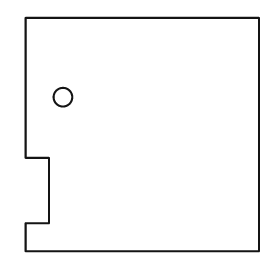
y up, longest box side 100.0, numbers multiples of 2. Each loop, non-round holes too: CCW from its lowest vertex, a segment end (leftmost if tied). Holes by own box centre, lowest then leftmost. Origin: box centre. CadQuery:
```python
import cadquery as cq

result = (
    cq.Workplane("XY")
    .moveTo(-50.0, -50.0)
    .lineTo(50.0, -50.0)
    .lineTo(50.0, 50.0)
    .lineTo(-50.0, 50.0)
    .lineTo(-50.0, -10.0)
    .lineTo(-40.0, -10.0)
    .lineTo(-40.0, -38.0)
    .lineTo(-50.0, -38.0)
    .close()
    .moveTo(-34.0, 16.0)
    .circle(4.0)
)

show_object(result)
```